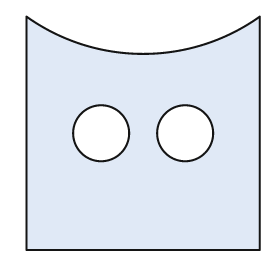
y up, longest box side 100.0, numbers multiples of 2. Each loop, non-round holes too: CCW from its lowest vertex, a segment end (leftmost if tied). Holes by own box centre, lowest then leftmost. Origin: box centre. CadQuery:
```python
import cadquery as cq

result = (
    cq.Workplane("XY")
    .moveTo(-50.0, -50.0)
    .lineTo(50.0, -50.0)
    .lineTo(50.0, 50.0)
    .threePointArc((0.0, 34.0), (-50.0, 50.0))
    .close()
    .moveTo(-18.0, 0.0)
    .circle(12.0)
    .moveTo(18.0, 0.0)
    .circle(12.0)
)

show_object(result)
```